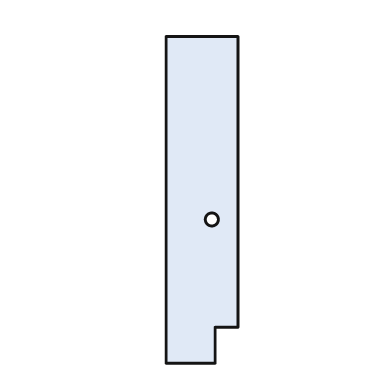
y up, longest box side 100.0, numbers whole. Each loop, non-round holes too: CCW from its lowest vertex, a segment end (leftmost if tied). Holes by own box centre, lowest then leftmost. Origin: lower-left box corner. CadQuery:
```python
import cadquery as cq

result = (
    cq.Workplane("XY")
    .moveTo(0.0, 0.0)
    .lineTo(15.0, 0.0)
    .lineTo(15.0, 11.0)
    .lineTo(22.0, 11.0)
    .lineTo(22.0, 100.0)
    .lineTo(0.0, 100.0)
    .close()
    .moveTo(14.0, 44.0)
    .circle(2.0)
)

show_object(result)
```